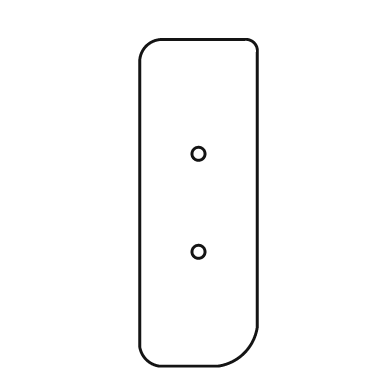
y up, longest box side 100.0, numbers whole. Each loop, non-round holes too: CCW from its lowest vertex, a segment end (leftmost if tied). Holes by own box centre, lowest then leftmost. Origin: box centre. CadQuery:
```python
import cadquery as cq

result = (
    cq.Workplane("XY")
    .moveTo(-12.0, -50.0)
    .lineTo(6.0, -50.0)
    .threePointArc((14.0, -46.0), (18.0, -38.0))
    .lineTo(18.0, 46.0)
    .threePointArc((17.0, 49.0), (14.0, 50.0))
    .lineTo(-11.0, 50.0)
    .threePointArc((-16.0, 48.0), (-18.0, 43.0))
    .lineTo(-18.0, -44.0)
    .threePointArc((-16.0, -48.0), (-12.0, -50.0))
    .close()
    .moveTo(0.0, -15.0)
    .circle(2.0)
    .moveTo(0.0, 15.0)
    .circle(2.0)
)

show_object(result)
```